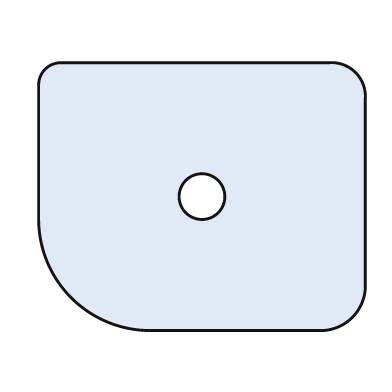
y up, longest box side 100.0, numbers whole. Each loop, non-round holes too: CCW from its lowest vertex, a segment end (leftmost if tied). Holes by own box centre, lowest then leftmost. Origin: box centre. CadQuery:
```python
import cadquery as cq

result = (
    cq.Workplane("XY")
    .moveTo(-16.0, -41.0)
    .lineTo(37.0, -41.0)
    .threePointArc((46.0, -37.0), (50.0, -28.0))
    .lineTo(50.0, 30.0)
    .threePointArc((47.0, 38.0), (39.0, 41.0))
    .lineTo(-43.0, 41.0)
    .threePointArc((-48.0, 39.0), (-50.0, 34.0))
    .lineTo(-50.0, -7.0)
    .threePointArc((-40.0, -31.0), (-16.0, -41.0))
    .close()
    .moveTo(0.0, 0.0)
    .circle(7.0)
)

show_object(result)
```